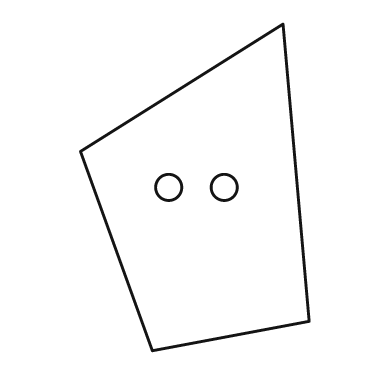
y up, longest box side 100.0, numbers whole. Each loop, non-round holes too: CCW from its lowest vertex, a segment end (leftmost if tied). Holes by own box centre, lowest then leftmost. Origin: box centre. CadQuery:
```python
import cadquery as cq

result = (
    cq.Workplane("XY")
    .moveTo(-13.0, -50.0)
    .lineTo(35.0, -41.0)
    .lineTo(27.0, 50.0)
    .lineTo(-35.0, 11.0)
    .close()
    .moveTo(-8.0, 0.0)
    .circle(4.0)
    .moveTo(9.0, 0.0)
    .circle(4.0)
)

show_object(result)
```